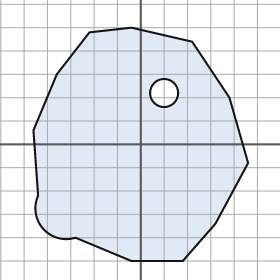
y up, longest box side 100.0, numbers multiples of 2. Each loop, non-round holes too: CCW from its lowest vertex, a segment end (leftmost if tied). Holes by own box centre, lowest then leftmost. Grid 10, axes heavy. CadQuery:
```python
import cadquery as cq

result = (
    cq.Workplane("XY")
    .moveTo(-4.0, -50.0)
    .lineTo(18.0, -50.0)
    .lineTo(32.0, -34.0)
    .lineTo(46.0, -8.0)
    .lineTo(38.0, 20.0)
    .lineTo(22.0, 44.0)
    .lineTo(-4.0, 50.0)
    .lineTo(-22.0, 48.0)
    .lineTo(-36.0, 30.0)
    .lineTo(-46.0, 6.0)
    .lineTo(-44.0, -22.0)
    .threePointArc((-42.0, -36.0), (-28.0, -40.0))
    .close()
    .moveTo(10.0, 22.0)
    .circle(6.0)
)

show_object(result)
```